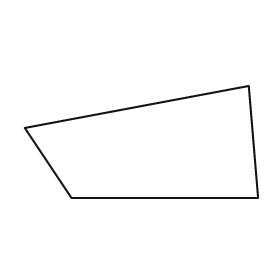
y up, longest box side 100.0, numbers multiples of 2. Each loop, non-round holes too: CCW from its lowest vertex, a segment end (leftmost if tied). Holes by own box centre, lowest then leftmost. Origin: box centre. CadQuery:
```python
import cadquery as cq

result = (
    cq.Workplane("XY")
    .moveTo(-30.0, -24.0)
    .lineTo(50.0, -24.0)
    .lineTo(46.0, 24.0)
    .lineTo(-50.0, 6.0)
    .close()
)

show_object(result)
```